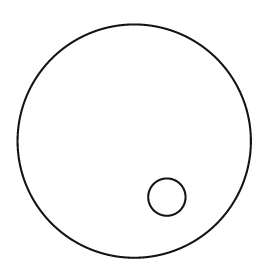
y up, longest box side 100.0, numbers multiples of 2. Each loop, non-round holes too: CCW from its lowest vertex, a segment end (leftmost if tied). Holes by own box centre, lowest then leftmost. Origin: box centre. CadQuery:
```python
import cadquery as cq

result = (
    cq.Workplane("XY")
    .moveTo(0.0, 0.0)
    .circle(50.0)
    .moveTo(14.0, -24.0)
    .circle(8.0)
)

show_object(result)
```